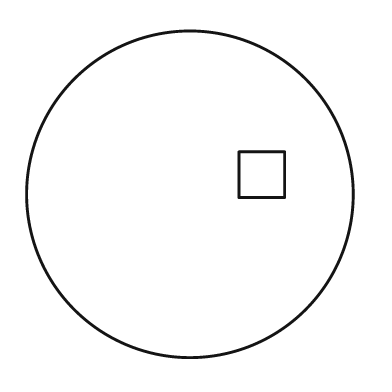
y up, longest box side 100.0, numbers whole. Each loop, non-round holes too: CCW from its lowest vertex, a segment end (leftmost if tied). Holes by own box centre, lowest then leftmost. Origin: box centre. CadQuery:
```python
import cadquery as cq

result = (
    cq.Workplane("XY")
    .moveTo(0.0, 0.0)
    .circle(50.0)
    .moveTo(15.0, -1.0)
    .lineTo(29.0, -1.0)
    .lineTo(29.0, 13.0)
    .lineTo(15.0, 13.0)
    .close()
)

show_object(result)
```